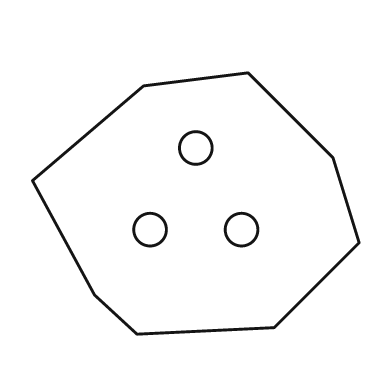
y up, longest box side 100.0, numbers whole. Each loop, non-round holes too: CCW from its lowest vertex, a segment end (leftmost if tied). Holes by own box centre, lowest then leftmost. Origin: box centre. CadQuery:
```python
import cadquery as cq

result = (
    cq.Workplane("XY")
    .moveTo(-18.0, -40.0)
    .lineTo(24.0, -38.0)
    .lineTo(50.0, -12.0)
    .lineTo(42.0, 14.0)
    .lineTo(16.0, 40.0)
    .lineTo(-16.0, 36.0)
    .lineTo(-50.0, 7.0)
    .lineTo(-31.0, -28.0)
    .close()
    .moveTo(-14.0, -8.0)
    .circle(5.0)
    .moveTo(14.0, -8.0)
    .circle(5.0)
    .moveTo(0.0, 17.0)
    .circle(5.0)
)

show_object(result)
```